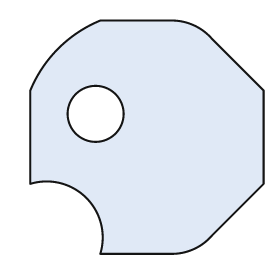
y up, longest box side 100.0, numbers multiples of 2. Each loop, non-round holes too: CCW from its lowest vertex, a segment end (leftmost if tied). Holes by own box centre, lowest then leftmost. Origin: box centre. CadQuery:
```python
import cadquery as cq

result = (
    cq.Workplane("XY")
    .moveTo(-20.0, -50.0)
    .lineTo(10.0, -50.0)
    .threePointArc((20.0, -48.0), (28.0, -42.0))
    .lineTo(50.0, -20.0)
    .lineTo(50.0, 20.0)
    .lineTo(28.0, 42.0)
    .threePointArc((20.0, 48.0), (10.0, 50.0))
    .lineTo(-20.0, 50.0)
    .threePointArc((-38.0, 38.0), (-50.0, 20.0))
    .lineTo(-50.0, -20.0)
    .threePointArc((-26.0, -26.0), (-20.0, -50.0))
    .close()
    .moveTo(-22.0, 10.0)
    .circle(12.0)
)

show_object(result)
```